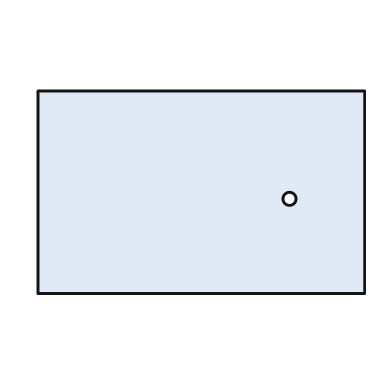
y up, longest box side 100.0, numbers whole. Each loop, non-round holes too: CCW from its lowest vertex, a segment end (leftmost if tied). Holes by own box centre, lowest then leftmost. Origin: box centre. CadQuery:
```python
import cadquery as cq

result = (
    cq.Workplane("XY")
    .moveTo(-50.0, -31.0)
    .lineTo(50.0, -31.0)
    .lineTo(50.0, 31.0)
    .lineTo(-50.0, 31.0)
    .close()
    .moveTo(27.0, -2.0)
    .circle(2.0)
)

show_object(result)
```